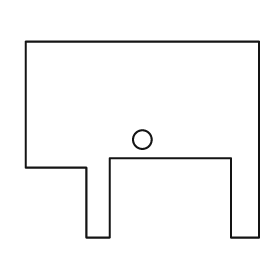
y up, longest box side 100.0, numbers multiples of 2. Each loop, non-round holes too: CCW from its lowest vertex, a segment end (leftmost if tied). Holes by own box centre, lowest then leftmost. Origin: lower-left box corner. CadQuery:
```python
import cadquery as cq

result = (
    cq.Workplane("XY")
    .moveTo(26.0, 0.0)
    .lineTo(36.0, 0.0)
    .lineTo(36.0, 34.0)
    .lineTo(88.0, 34.0)
    .lineTo(88.0, 0.0)
    .lineTo(100.0, 0.0)
    .lineTo(100.0, 84.0)
    .lineTo(0.0, 84.0)
    .lineTo(0.0, 30.0)
    .lineTo(26.0, 30.0)
    .close()
    .moveTo(50.0, 42.0)
    .circle(4.0)
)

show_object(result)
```